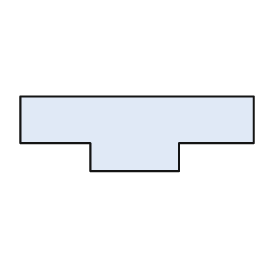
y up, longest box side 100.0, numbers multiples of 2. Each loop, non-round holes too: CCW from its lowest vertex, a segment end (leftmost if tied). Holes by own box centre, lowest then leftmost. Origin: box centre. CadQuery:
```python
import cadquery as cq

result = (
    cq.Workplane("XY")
    .moveTo(-20.0, -16.0)
    .lineTo(18.0, -16.0)
    .lineTo(18.0, -4.0)
    .lineTo(50.0, -4.0)
    .lineTo(50.0, 16.0)
    .lineTo(-50.0, 16.0)
    .lineTo(-50.0, -4.0)
    .lineTo(-20.0, -4.0)
    .close()
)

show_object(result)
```